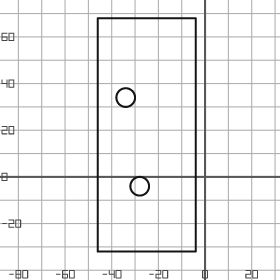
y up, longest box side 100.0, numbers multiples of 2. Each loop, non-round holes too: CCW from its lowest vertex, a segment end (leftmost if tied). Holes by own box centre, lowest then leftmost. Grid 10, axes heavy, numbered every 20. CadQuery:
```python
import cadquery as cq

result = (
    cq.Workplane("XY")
    .moveTo(-46.0, -32.0)
    .lineTo(-4.0, -32.0)
    .lineTo(-4.0, 68.0)
    .lineTo(-46.0, 68.0)
    .close()
    .moveTo(-28.0, -4.0)
    .circle(4.0)
    .moveTo(-34.0, 34.0)
    .circle(4.0)
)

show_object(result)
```